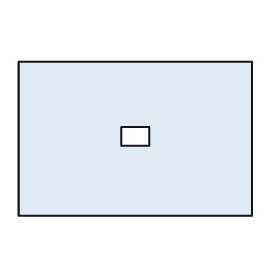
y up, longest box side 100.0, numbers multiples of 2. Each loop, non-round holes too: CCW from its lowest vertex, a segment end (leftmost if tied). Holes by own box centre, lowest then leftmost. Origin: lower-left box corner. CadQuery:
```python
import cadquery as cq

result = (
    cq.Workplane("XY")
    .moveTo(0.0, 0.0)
    .lineTo(100.0, 0.0)
    .lineTo(100.0, 66.0)
    .lineTo(0.0, 66.0)
    .close()
    .moveTo(44.0, 30.0)
    .lineTo(56.0, 30.0)
    .lineTo(56.0, 38.0)
    .lineTo(44.0, 38.0)
    .close()
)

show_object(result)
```